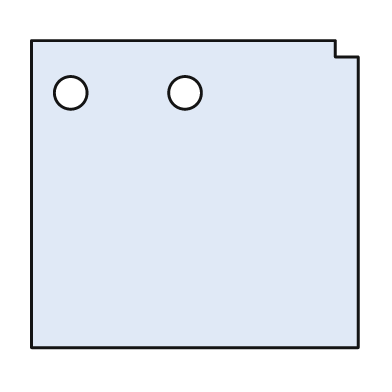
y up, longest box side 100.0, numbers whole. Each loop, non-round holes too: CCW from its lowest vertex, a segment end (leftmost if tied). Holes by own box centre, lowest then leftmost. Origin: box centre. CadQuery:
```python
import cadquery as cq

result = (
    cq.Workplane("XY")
    .moveTo(-50.0, -47.0)
    .lineTo(50.0, -47.0)
    .lineTo(50.0, 42.0)
    .lineTo(43.0, 42.0)
    .lineTo(43.0, 47.0)
    .lineTo(-50.0, 47.0)
    .close()
    .moveTo(-38.0, 31.0)
    .circle(5.0)
    .moveTo(-3.0, 31.0)
    .circle(5.0)
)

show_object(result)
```